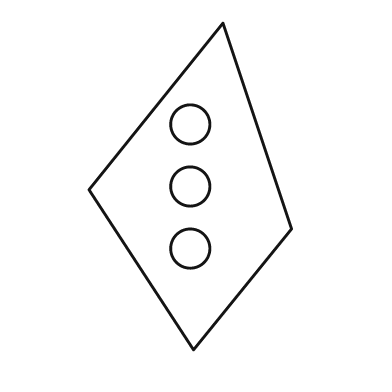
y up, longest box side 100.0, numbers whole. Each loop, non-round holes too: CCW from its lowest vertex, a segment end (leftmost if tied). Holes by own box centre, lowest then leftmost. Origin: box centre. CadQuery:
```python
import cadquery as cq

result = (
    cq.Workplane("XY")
    .moveTo(1.0, -50.0)
    .lineTo(31.0, -13.0)
    .lineTo(10.0, 50.0)
    .lineTo(-31.0, -1.0)
    .close()
    .moveTo(0.0, -19.0)
    .circle(6.0)
    .moveTo(0.0, 0.0)
    .circle(6.0)
    .moveTo(0.0, 19.0)
    .circle(6.0)
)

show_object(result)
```